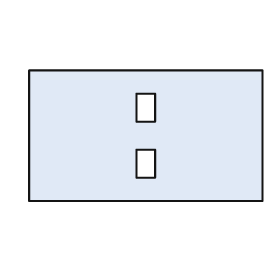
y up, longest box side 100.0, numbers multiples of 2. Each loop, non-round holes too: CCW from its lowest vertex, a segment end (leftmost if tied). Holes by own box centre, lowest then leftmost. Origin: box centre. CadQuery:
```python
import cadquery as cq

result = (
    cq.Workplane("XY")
    .moveTo(-50.0, -28.0)
    .lineTo(50.0, -28.0)
    .lineTo(50.0, 28.0)
    .lineTo(-50.0, 28.0)
    .close()
    .moveTo(-4.0, -18.0)
    .lineTo(4.0, -18.0)
    .lineTo(4.0, -6.0)
    .lineTo(-4.0, -6.0)
    .close()
    .moveTo(-4.0, 6.0)
    .lineTo(4.0, 6.0)
    .lineTo(4.0, 18.0)
    .lineTo(-4.0, 18.0)
    .close()
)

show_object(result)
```